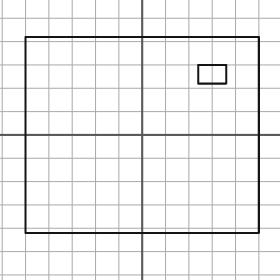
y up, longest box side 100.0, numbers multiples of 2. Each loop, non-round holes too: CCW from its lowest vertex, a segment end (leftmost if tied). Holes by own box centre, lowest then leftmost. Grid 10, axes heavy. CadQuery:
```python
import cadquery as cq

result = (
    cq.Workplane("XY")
    .moveTo(-50.0, -42.0)
    .lineTo(50.0, -42.0)
    .lineTo(50.0, 42.0)
    .lineTo(-50.0, 42.0)
    .close()
    .moveTo(24.0, 22.0)
    .lineTo(36.0, 22.0)
    .lineTo(36.0, 30.0)
    .lineTo(24.0, 30.0)
    .close()
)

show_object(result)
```